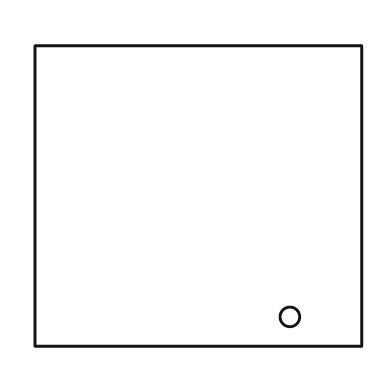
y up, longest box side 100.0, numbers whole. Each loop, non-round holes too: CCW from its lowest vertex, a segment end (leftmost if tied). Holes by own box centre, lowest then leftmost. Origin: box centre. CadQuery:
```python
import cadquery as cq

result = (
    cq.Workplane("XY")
    .moveTo(-50.0, -46.0)
    .lineTo(50.0, -46.0)
    .lineTo(50.0, 46.0)
    .lineTo(-50.0, 46.0)
    .close()
    .moveTo(28.0, -37.0)
    .circle(3.0)
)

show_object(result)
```